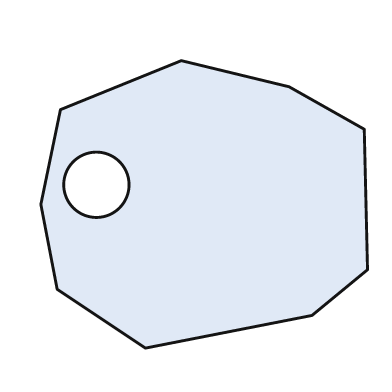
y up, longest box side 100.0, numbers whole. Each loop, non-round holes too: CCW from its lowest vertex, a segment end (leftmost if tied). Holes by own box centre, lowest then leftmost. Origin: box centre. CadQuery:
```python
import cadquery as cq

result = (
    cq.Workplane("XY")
    .moveTo(-18.0, -44.0)
    .lineTo(33.0, -34.0)
    .lineTo(50.0, -20.0)
    .lineTo(49.0, 23.0)
    .lineTo(26.0, 36.0)
    .lineTo(-7.0, 44.0)
    .lineTo(-44.0, 29.0)
    .lineTo(-50.0, 0.0)
    .lineTo(-45.0, -26.0)
    .close()
    .moveTo(-33.0, 6.0)
    .circle(10.0)
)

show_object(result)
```